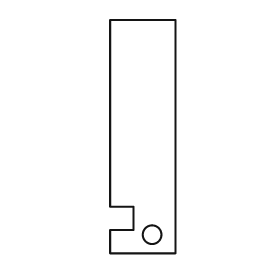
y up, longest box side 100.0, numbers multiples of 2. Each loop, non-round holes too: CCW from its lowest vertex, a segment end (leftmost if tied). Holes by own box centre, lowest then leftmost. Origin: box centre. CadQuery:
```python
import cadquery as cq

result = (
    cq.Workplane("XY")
    .moveTo(-14.0, -50.0)
    .lineTo(14.0, -50.0)
    .lineTo(14.0, 50.0)
    .lineTo(-14.0, 50.0)
    .lineTo(-14.0, -30.0)
    .lineTo(-4.0, -30.0)
    .lineTo(-4.0, -40.0)
    .lineTo(-14.0, -40.0)
    .close()
    .moveTo(4.0, -42.0)
    .circle(4.0)
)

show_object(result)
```